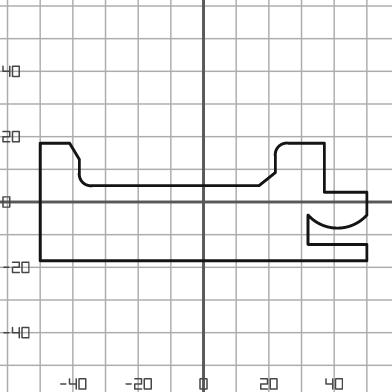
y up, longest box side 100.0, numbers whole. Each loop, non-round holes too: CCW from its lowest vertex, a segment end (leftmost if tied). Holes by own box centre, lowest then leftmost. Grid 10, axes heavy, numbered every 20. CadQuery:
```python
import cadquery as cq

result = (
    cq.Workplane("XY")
    .moveTo(-50.0, -18.0)
    .lineTo(50.0, -18.0)
    .lineTo(50.0, -13.0)
    .lineTo(32.0, -13.0)
    .lineTo(32.0, -4.0)
    .threePointArc((41.0, -8.0), (50.0, -4.0))
    .lineTo(50.0, 3.0)
    .lineTo(37.0, 3.0)
    .lineTo(37.0, 18.0)
    .lineTo(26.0, 18.0)
    .threePointArc((23.0, 17.0), (22.0, 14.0))
    .lineTo(22.0, 9.0)
    .lineTo(17.0, 5.0)
    .lineTo(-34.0, 5.0)
    .threePointArc((-37.0, 6.0), (-38.0, 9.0))
    .lineTo(-38.0, 13.0)
    .lineTo(-41.0, 18.0)
    .lineTo(-50.0, 18.0)
    .close()
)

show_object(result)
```